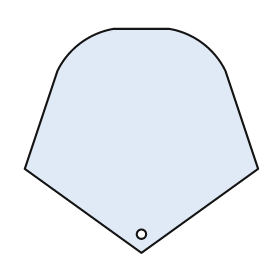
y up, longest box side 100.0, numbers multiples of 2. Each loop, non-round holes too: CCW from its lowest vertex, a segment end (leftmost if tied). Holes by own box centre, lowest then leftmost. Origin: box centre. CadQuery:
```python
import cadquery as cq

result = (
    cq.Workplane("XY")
    .moveTo(0.0, -48.0)
    .lineTo(50.0, -12.0)
    .lineTo(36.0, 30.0)
    .threePointArc((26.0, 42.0), (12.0, 48.0))
    .lineTo(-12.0, 48.0)
    .threePointArc((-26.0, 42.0), (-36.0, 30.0))
    .lineTo(-50.0, -12.0)
    .close()
    .moveTo(0.0, -40.0)
    .circle(2.0)
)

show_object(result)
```